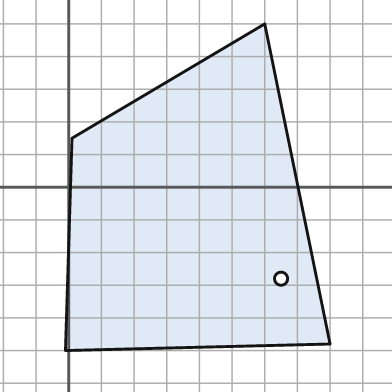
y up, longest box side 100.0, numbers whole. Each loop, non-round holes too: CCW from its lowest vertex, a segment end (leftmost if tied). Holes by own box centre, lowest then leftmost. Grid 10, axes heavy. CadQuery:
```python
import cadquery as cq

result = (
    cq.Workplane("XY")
    .moveTo(-1.0, -50.0)
    .lineTo(80.0, -48.0)
    .lineTo(60.0, 50.0)
    .lineTo(1.0, 15.0)
    .close()
    .moveTo(65.0, -28.0)
    .circle(2.0)
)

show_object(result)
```